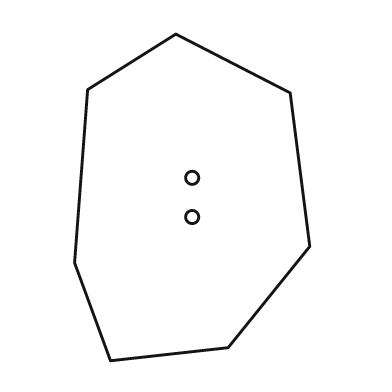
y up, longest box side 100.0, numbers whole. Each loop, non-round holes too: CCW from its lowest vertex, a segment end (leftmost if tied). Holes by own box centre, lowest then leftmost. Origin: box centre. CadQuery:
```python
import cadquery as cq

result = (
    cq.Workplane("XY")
    .moveTo(-25.0, -50.0)
    .lineTo(11.0, -46.0)
    .lineTo(36.0, -15.0)
    .lineTo(30.0, 32.0)
    .lineTo(-5.0, 50.0)
    .lineTo(-32.0, 33.0)
    .lineTo(-36.0, -20.0)
    .close()
    .moveTo(0.0, -6.0)
    .circle(2.0)
    .moveTo(0.0, 6.0)
    .circle(2.0)
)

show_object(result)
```